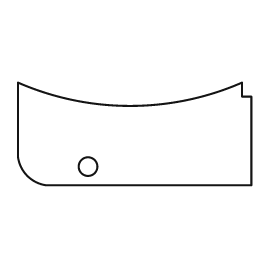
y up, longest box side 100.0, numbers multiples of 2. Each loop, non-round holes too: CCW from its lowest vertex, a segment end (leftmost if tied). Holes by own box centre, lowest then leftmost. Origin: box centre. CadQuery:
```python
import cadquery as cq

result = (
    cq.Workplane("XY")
    .moveTo(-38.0, -22.0)
    .lineTo(50.0, -22.0)
    .lineTo(50.0, 16.0)
    .lineTo(46.0, 16.0)
    .lineTo(46.0, 22.0)
    .threePointArc((-2.0, 12.0), (-50.0, 22.0))
    .lineTo(-50.0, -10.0)
    .threePointArc((-46.0, -18.0), (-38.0, -22.0))
    .close()
    .moveTo(-20.0, -14.0)
    .circle(4.0)
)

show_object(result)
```